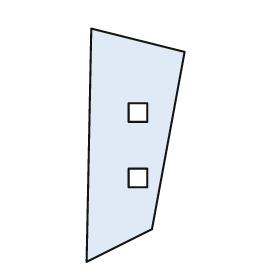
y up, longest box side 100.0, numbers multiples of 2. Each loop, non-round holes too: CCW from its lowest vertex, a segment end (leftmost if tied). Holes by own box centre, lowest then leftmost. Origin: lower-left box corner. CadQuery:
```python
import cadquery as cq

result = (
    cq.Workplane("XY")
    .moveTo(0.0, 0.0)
    .lineTo(28.0, 14.0)
    .lineTo(42.0, 90.0)
    .lineTo(2.0, 100.0)
    .close()
    .moveTo(18.0, 32.0)
    .lineTo(26.0, 32.0)
    .lineTo(26.0, 40.0)
    .lineTo(18.0, 40.0)
    .close()
    .moveTo(18.0, 60.0)
    .lineTo(26.0, 60.0)
    .lineTo(26.0, 68.0)
    .lineTo(18.0, 68.0)
    .close()
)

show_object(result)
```